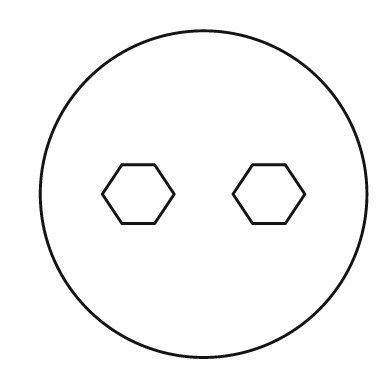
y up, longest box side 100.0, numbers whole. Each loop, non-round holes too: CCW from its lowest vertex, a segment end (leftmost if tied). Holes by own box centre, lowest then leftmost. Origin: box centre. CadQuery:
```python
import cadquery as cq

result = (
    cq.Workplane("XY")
    .moveTo(0.0, 0.0)
    .circle(50.0)
    .moveTo(-25.0, -9.0)
    .lineTo(-15.0, -9.0)
    .lineTo(-9.0, 0.0)
    .lineTo(-15.0, 9.0)
    .lineTo(-25.0, 9.0)
    .lineTo(-31.0, 0.0)
    .close()
    .moveTo(15.0, -9.0)
    .lineTo(25.0, -9.0)
    .lineTo(31.0, 0.0)
    .lineTo(25.0, 9.0)
    .lineTo(15.0, 9.0)
    .lineTo(9.0, 0.0)
    .close()
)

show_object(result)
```